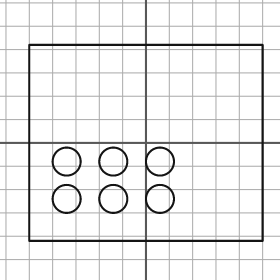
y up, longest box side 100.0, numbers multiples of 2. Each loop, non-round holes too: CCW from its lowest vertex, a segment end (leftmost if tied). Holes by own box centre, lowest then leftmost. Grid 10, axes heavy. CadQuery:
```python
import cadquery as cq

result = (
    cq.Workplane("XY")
    .moveTo(-50.0, -42.0)
    .lineTo(50.0, -42.0)
    .lineTo(50.0, 42.0)
    .lineTo(-50.0, 42.0)
    .close()
    .moveTo(-34.0, -24.0)
    .circle(6.0)
    .moveTo(-14.0, -24.0)
    .circle(6.0)
    .moveTo(6.0, -24.0)
    .circle(6.0)
    .moveTo(-34.0, -8.0)
    .circle(6.0)
    .moveTo(-14.0, -8.0)
    .circle(6.0)
    .moveTo(6.0, -8.0)
    .circle(6.0)
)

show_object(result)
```